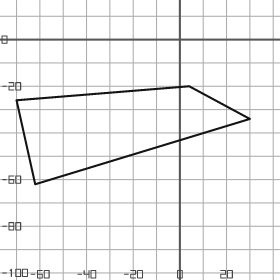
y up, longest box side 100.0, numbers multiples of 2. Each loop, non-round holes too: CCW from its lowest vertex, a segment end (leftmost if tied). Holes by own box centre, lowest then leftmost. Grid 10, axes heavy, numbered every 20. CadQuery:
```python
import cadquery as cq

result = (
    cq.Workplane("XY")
    .moveTo(-62.0, -62.0)
    .lineTo(30.0, -34.0)
    .lineTo(4.0, -20.0)
    .lineTo(-70.0, -26.0)
    .close()
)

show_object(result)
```